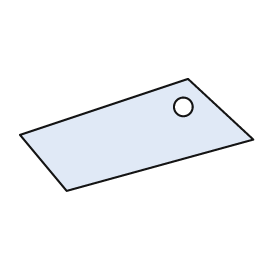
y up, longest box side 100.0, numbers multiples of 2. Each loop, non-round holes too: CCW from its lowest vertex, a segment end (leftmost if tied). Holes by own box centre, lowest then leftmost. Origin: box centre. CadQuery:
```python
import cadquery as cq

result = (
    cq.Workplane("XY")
    .moveTo(-30.0, -24.0)
    .lineTo(50.0, -2.0)
    .lineTo(22.0, 24.0)
    .lineTo(-50.0, 0.0)
    .close()
    .moveTo(20.0, 12.0)
    .circle(4.0)
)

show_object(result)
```